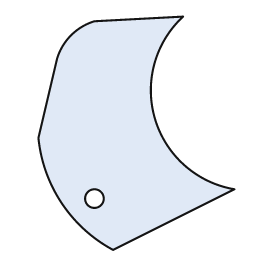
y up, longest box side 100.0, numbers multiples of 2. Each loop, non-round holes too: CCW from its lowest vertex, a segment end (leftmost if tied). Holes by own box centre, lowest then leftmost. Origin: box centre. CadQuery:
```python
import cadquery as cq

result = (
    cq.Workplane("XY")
    .moveTo(-10.0, -50.0)
    .lineTo(42.0, -24.0)
    .threePointArc((8.0, 6.0), (20.0, 50.0))
    .lineTo(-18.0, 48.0)
    .threePointArc((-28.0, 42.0), (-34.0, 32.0))
    .lineTo(-42.0, -2.0)
    .threePointArc((-32.0, -30.0), (-10.0, -50.0))
    .close()
    .moveTo(-18.0, -28.0)
    .circle(4.0)
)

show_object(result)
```